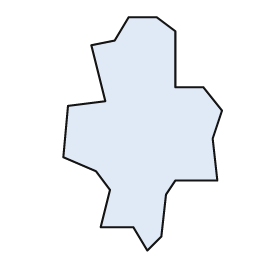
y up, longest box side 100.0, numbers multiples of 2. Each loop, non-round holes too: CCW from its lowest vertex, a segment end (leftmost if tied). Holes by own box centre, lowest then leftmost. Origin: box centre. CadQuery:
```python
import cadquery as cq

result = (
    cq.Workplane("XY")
    .moveTo(2.0, -50.0)
    .lineTo(8.0, -44.0)
    .lineTo(10.0, -26.0)
    .lineTo(14.0, -20.0)
    .lineTo(32.0, -20.0)
    .lineTo(30.0, -2.0)
    .lineTo(34.0, 10.0)
    .lineTo(26.0, 20.0)
    .lineTo(14.0, 20.0)
    .lineTo(14.0, 44.0)
    .lineTo(6.0, 50.0)
    .lineTo(-6.0, 50.0)
    .lineTo(-12.0, 40.0)
    .lineTo(-22.0, 38.0)
    .lineTo(-16.0, 14.0)
    .lineTo(-32.0, 12.0)
    .lineTo(-34.0, -10.0)
    .lineTo(-20.0, -16.0)
    .lineTo(-14.0, -24.0)
    .lineTo(-18.0, -40.0)
    .lineTo(-4.0, -40.0)
    .close()
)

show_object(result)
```